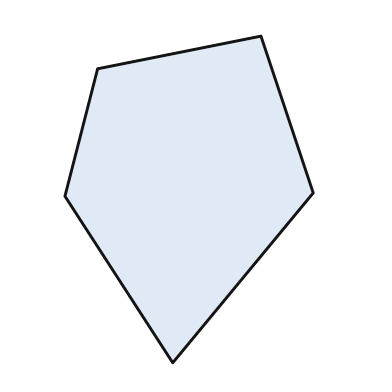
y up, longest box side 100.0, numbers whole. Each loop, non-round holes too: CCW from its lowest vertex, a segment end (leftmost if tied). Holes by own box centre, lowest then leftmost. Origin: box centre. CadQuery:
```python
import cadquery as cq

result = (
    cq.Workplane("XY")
    .moveTo(-5.0, -50.0)
    .lineTo(38.0, 2.0)
    .lineTo(22.0, 50.0)
    .lineTo(-28.0, 40.0)
    .lineTo(-38.0, 1.0)
    .close()
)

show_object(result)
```